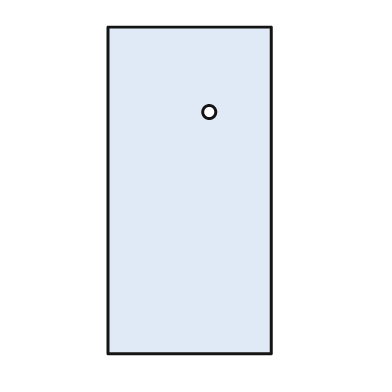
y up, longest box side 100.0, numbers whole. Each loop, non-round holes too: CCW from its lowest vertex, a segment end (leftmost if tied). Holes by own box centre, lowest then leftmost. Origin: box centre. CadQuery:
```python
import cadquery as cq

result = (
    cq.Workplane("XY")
    .moveTo(-25.0, -50.0)
    .lineTo(25.0, -50.0)
    .lineTo(25.0, 50.0)
    .lineTo(-25.0, 50.0)
    .close()
    .moveTo(6.0, 24.0)
    .circle(2.0)
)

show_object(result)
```